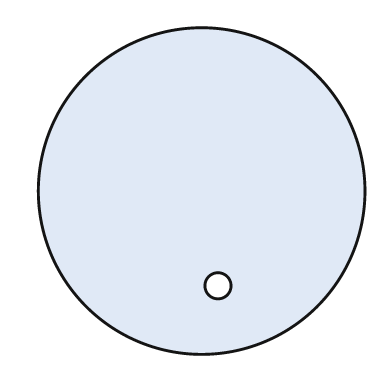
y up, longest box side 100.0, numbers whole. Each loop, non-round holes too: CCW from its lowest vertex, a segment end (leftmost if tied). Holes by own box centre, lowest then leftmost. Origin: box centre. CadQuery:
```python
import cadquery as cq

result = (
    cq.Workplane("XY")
    .moveTo(0.0, 0.0)
    .circle(50.0)
    .moveTo(5.0, -29.0)
    .circle(4.0)
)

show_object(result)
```